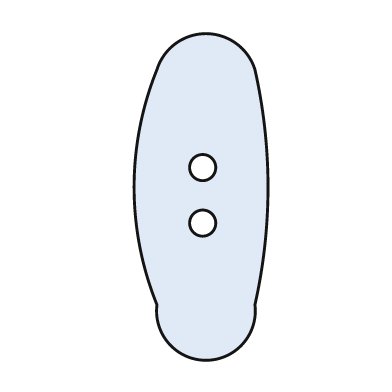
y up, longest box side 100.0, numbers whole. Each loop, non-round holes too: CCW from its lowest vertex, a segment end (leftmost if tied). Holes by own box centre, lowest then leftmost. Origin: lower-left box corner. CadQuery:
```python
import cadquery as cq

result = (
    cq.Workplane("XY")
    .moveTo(7.0, 17.0)
    .threePointArc((22.0, 0.0), (37.0, 17.0))
    .threePointArc((41.0, 53.0), (37.0, 89.0))
    .threePointArc((22.0, 100.0), (7.0, 89.0))
    .threePointArc((0.0, 53.0), (7.0, 17.0))
    .close()
    .moveTo(21.0, 42.0)
    .circle(4.0)
    .moveTo(21.0, 59.0)
    .circle(4.0)
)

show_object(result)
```